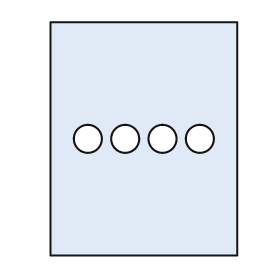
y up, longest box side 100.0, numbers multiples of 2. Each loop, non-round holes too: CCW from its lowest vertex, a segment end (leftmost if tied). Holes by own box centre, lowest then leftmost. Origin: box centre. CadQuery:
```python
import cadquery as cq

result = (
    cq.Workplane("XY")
    .moveTo(-40.0, -50.0)
    .lineTo(40.0, -50.0)
    .lineTo(40.0, 50.0)
    .lineTo(-40.0, 50.0)
    .close()
    .moveTo(-24.0, 0.0)
    .circle(6.0)
    .moveTo(-8.0, 0.0)
    .circle(6.0)
    .moveTo(8.0, 0.0)
    .circle(6.0)
    .moveTo(24.0, 0.0)
    .circle(6.0)
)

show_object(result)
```